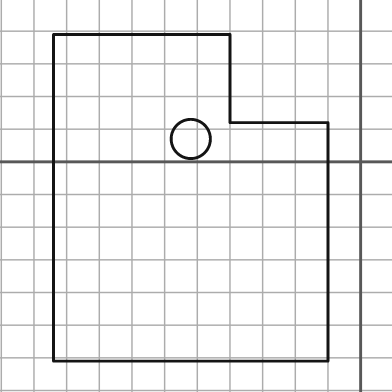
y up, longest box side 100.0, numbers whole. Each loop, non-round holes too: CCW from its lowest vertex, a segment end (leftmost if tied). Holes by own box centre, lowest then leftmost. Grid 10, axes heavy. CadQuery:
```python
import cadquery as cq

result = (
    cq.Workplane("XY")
    .moveTo(-94.0, -61.0)
    .lineTo(-10.0, -61.0)
    .lineTo(-10.0, 12.0)
    .lineTo(-40.0, 12.0)
    .lineTo(-40.0, 39.0)
    .lineTo(-94.0, 39.0)
    .close()
    .moveTo(-52.0, 7.0)
    .circle(6.0)
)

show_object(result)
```